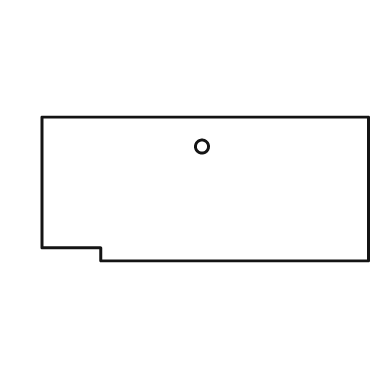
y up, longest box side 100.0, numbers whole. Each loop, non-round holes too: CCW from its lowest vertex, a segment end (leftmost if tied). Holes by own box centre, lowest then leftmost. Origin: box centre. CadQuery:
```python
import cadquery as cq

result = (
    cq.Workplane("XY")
    .moveTo(-32.0, -22.0)
    .lineTo(50.0, -22.0)
    .lineTo(50.0, 22.0)
    .lineTo(-50.0, 22.0)
    .lineTo(-50.0, -18.0)
    .lineTo(-32.0, -18.0)
    .close()
    .moveTo(-1.0, 13.0)
    .circle(2.0)
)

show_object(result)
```